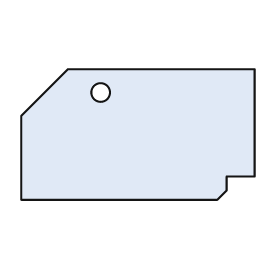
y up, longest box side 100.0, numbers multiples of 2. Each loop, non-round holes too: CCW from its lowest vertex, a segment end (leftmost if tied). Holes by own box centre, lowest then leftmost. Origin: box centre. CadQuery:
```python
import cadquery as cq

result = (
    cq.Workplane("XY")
    .moveTo(-50.0, -28.0)
    .lineTo(34.0, -28.0)
    .lineTo(38.0, -24.0)
    .lineTo(38.0, -18.0)
    .lineTo(50.0, -18.0)
    .lineTo(50.0, 28.0)
    .lineTo(-30.0, 28.0)
    .lineTo(-50.0, 8.0)
    .close()
    .moveTo(-16.0, 18.0)
    .circle(4.0)
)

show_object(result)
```